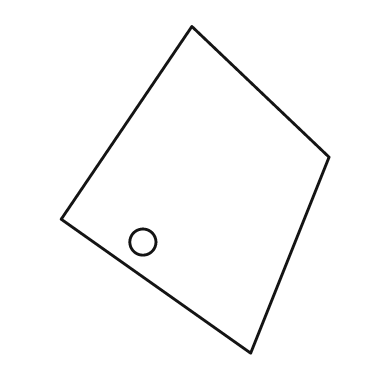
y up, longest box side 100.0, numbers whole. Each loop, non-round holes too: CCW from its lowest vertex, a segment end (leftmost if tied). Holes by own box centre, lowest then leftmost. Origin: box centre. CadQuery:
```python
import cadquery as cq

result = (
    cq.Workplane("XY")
    .moveTo(17.0, -50.0)
    .lineTo(41.0, 10.0)
    .lineTo(-1.0, 50.0)
    .lineTo(-41.0, -9.0)
    .close()
    .moveTo(-16.0, -16.0)
    .circle(4.0)
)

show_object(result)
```